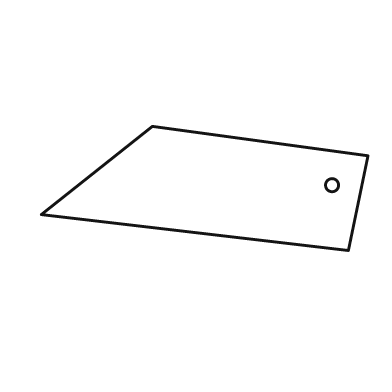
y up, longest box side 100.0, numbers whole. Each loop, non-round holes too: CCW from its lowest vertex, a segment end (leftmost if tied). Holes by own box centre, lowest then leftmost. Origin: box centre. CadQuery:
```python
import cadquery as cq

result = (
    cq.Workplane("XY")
    .moveTo(44.0, -19.0)
    .lineTo(50.0, 10.0)
    .lineTo(-16.0, 19.0)
    .lineTo(-50.0, -8.0)
    .close()
    .moveTo(39.0, 1.0)
    .circle(2.0)
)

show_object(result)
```